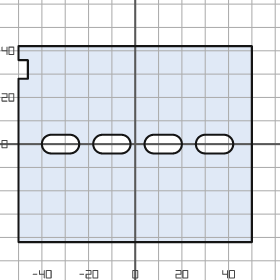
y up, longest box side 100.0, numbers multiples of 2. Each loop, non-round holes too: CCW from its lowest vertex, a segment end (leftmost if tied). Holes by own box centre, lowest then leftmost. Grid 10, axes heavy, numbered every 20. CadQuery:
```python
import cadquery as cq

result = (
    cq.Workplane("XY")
    .moveTo(-50.0, -42.0)
    .lineTo(50.0, -42.0)
    .lineTo(50.0, 42.0)
    .lineTo(-50.0, 42.0)
    .lineTo(-50.0, 36.0)
    .lineTo(-46.0, 36.0)
    .lineTo(-46.0, 28.0)
    .lineTo(-50.0, 28.0)
    .close()
    .moveTo(-36.0, -4.0)
    .lineTo(-28.0, -4.0)
    .threePointArc((-24.0, 0.0), (-28.0, 4.0))
    .lineTo(-36.0, 4.0)
    .threePointArc((-40.0, 0.0), (-36.0, -4.0))
    .close()
    .moveTo(-14.0, -4.0)
    .lineTo(-6.0, -4.0)
    .threePointArc((-2.0, 0.0), (-6.0, 4.0))
    .lineTo(-14.0, 4.0)
    .threePointArc((-18.0, 0.0), (-14.0, -4.0))
    .close()
    .moveTo(8.0, -4.0)
    .lineTo(16.0, -4.0)
    .threePointArc((20.0, 0.0), (16.0, 4.0))
    .lineTo(8.0, 4.0)
    .threePointArc((4.0, 0.0), (8.0, -4.0))
    .close()
    .moveTo(30.0, -4.0)
    .lineTo(38.0, -4.0)
    .threePointArc((42.0, 0.0), (38.0, 4.0))
    .lineTo(30.0, 4.0)
    .threePointArc((26.0, 0.0), (30.0, -4.0))
    .close()
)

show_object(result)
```